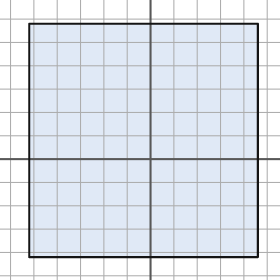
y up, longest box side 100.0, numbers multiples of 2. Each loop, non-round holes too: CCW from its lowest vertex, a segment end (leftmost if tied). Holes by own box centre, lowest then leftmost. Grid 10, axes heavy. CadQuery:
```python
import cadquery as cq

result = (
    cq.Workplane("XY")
    .moveTo(-52.0, -42.0)
    .lineTo(46.0, -42.0)
    .lineTo(46.0, 58.0)
    .lineTo(-52.0, 58.0)
    .close()
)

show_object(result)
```